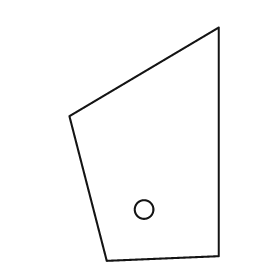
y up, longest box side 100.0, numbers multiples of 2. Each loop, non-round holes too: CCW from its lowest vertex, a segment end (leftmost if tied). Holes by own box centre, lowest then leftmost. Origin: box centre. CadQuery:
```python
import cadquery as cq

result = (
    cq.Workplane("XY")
    .moveTo(-16.0, -50.0)
    .lineTo(32.0, -48.0)
    .lineTo(32.0, 50.0)
    .lineTo(-32.0, 12.0)
    .close()
    .moveTo(0.0, -28.0)
    .circle(4.0)
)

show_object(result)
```